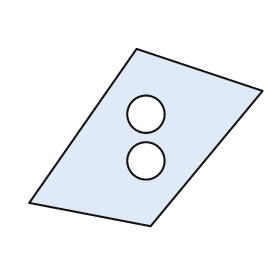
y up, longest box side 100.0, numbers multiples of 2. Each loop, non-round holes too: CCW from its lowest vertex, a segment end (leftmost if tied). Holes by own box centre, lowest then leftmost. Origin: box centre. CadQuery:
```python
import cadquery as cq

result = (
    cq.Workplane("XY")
    .moveTo(2.0, -38.0)
    .lineTo(50.0, 20.0)
    .lineTo(-4.0, 38.0)
    .lineTo(-50.0, -28.0)
    .close()
    .moveTo(0.0, -10.0)
    .circle(8.0)
    .moveTo(0.0, 10.0)
    .circle(8.0)
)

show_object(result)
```